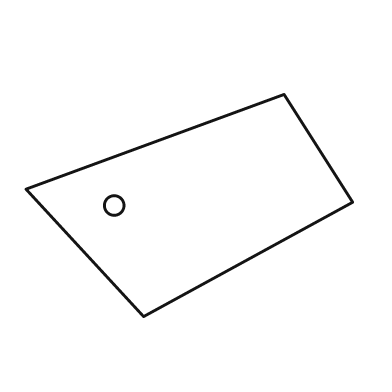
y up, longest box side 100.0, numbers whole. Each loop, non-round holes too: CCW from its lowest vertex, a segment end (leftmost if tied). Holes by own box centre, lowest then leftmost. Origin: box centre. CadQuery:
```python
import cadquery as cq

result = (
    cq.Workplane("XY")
    .moveTo(-14.0, -34.0)
    .lineTo(50.0, 1.0)
    .lineTo(29.0, 34.0)
    .lineTo(-50.0, 5.0)
    .close()
    .moveTo(-23.0, 0.0)
    .circle(3.0)
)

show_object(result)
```